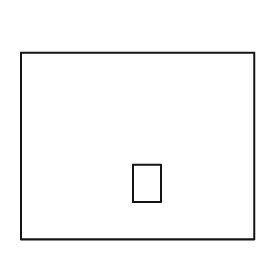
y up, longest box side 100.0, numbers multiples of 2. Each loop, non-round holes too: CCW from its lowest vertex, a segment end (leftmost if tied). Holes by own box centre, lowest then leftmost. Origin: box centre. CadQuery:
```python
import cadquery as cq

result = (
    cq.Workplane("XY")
    .moveTo(-50.0, -40.0)
    .lineTo(50.0, -40.0)
    .lineTo(50.0, 40.0)
    .lineTo(-50.0, 40.0)
    .close()
    .moveTo(-2.0, -24.0)
    .lineTo(10.0, -24.0)
    .lineTo(10.0, -8.0)
    .lineTo(-2.0, -8.0)
    .close()
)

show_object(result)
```